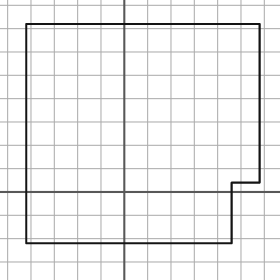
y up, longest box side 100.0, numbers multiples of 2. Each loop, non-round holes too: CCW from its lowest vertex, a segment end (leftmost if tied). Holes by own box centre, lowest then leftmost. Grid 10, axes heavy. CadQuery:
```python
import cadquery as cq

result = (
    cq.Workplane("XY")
    .moveTo(-42.0, -22.0)
    .lineTo(46.0, -22.0)
    .lineTo(46.0, 4.0)
    .lineTo(58.0, 4.0)
    .lineTo(58.0, 72.0)
    .lineTo(-42.0, 72.0)
    .close()
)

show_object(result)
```